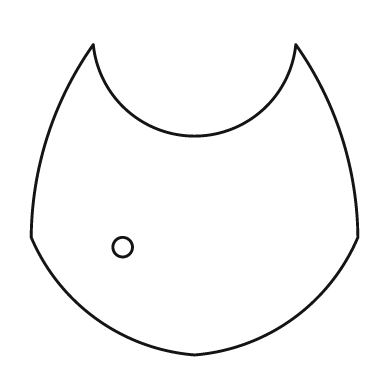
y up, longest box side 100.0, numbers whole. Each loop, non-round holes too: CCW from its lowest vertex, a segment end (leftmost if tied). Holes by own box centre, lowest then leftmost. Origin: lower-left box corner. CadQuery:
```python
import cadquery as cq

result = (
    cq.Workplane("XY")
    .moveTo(50.0, 0.0)
    .threePointArc((80.0, 11.0), (100.0, 36.0))
    .threePointArc((95.0, 67.0), (81.0, 95.0))
    .threePointArc((50.0, 67.0), (19.0, 95.0))
    .threePointArc((5.0, 67.0), (0.0, 36.0))
    .threePointArc((20.0, 11.0), (50.0, 0.0))
    .close()
    .moveTo(28.0, 33.0)
    .circle(3.0)
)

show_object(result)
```